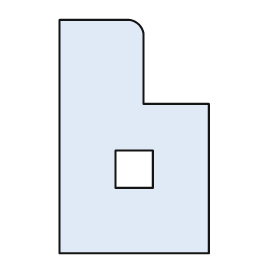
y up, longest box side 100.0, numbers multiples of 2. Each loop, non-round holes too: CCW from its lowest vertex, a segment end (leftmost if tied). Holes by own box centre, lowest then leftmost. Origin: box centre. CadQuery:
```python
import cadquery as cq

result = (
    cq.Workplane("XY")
    .moveTo(-32.0, -50.0)
    .lineTo(32.0, -50.0)
    .lineTo(32.0, 14.0)
    .lineTo(4.0, 14.0)
    .lineTo(4.0, 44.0)
    .threePointArc((2.0, 48.0), (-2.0, 50.0))
    .lineTo(-32.0, 50.0)
    .close()
    .moveTo(-8.0, -22.0)
    .lineTo(8.0, -22.0)
    .lineTo(8.0, -6.0)
    .lineTo(-8.0, -6.0)
    .close()
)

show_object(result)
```